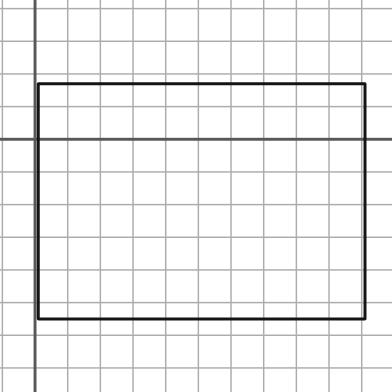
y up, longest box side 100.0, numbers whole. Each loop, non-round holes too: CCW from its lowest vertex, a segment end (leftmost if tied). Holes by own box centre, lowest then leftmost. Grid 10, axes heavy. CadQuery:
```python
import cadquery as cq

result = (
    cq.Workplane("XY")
    .moveTo(1.0, -55.0)
    .lineTo(101.0, -55.0)
    .lineTo(101.0, 17.0)
    .lineTo(1.0, 17.0)
    .close()
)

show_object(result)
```